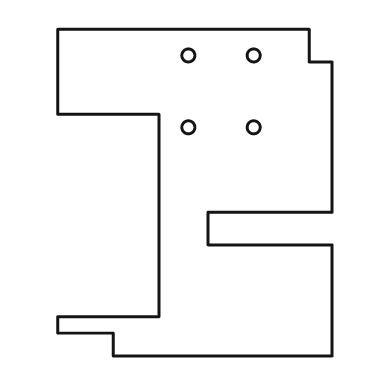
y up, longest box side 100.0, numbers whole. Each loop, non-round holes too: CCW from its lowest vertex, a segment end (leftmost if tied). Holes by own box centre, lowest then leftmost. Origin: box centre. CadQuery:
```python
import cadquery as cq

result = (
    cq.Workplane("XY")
    .moveTo(-25.0, -50.0)
    .lineTo(42.0, -50.0)
    .lineTo(42.0, -16.0)
    .lineTo(4.0, -16.0)
    .lineTo(4.0, -6.0)
    .lineTo(42.0, -6.0)
    .lineTo(42.0, 40.0)
    .lineTo(35.0, 40.0)
    .lineTo(35.0, 50.0)
    .lineTo(-42.0, 50.0)
    .lineTo(-42.0, 24.0)
    .lineTo(-11.0, 24.0)
    .lineTo(-11.0, -38.0)
    .lineTo(-42.0, -38.0)
    .lineTo(-42.0, -43.0)
    .lineTo(-25.0, -43.0)
    .close()
    .moveTo(-2.0, 20.0)
    .circle(2.0)
    .moveTo(18.0, 20.0)
    .circle(2.0)
    .moveTo(-2.0, 42.0)
    .circle(2.0)
    .moveTo(18.0, 42.0)
    .circle(2.0)
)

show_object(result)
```